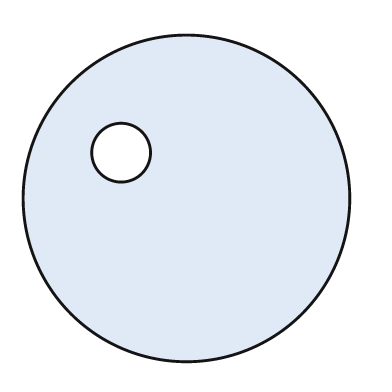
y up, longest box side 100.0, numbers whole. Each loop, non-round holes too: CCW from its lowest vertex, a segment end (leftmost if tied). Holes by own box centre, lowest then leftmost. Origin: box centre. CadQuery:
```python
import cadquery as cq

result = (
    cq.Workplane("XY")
    .moveTo(0.0, 0.0)
    .circle(50.0)
    .moveTo(-20.0, 14.0)
    .circle(9.0)
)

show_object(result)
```